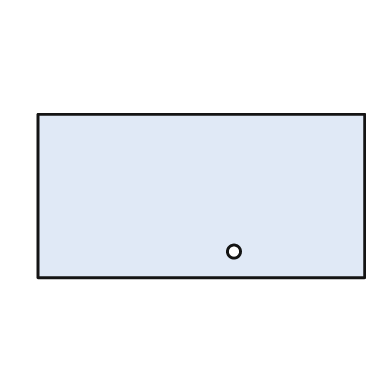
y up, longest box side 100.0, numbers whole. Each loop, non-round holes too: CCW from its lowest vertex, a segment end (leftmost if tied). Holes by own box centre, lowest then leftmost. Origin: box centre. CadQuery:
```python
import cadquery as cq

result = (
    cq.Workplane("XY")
    .moveTo(-50.0, -25.0)
    .lineTo(50.0, -25.0)
    .lineTo(50.0, 25.0)
    .lineTo(-50.0, 25.0)
    .close()
    .moveTo(10.0, -17.0)
    .circle(2.0)
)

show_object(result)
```